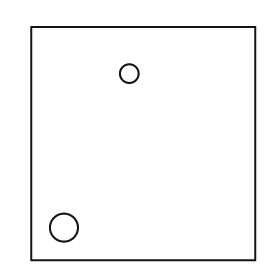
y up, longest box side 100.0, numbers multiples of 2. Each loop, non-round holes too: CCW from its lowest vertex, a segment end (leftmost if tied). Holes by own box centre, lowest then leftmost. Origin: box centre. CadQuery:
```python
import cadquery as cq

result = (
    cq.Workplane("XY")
    .moveTo(-48.0, -50.0)
    .lineTo(48.0, -50.0)
    .lineTo(48.0, 50.0)
    .lineTo(-48.0, 50.0)
    .close()
    .moveTo(-34.0, -36.0)
    .circle(6.0)
    .moveTo(-6.0, 30.0)
    .circle(4.0)
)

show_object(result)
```